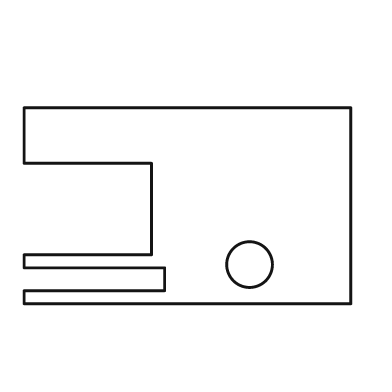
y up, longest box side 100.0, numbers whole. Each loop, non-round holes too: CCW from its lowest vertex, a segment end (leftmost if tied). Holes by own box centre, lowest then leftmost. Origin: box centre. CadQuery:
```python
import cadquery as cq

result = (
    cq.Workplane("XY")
    .moveTo(-50.0, -30.0)
    .lineTo(50.0, -30.0)
    .lineTo(50.0, 30.0)
    .lineTo(-50.0, 30.0)
    .lineTo(-50.0, 13.0)
    .lineTo(-11.0, 13.0)
    .lineTo(-11.0, -15.0)
    .lineTo(-50.0, -15.0)
    .lineTo(-50.0, -19.0)
    .lineTo(-7.0, -19.0)
    .lineTo(-7.0, -26.0)
    .lineTo(-50.0, -26.0)
    .close()
    .moveTo(19.0, -18.0)
    .circle(7.0)
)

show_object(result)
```